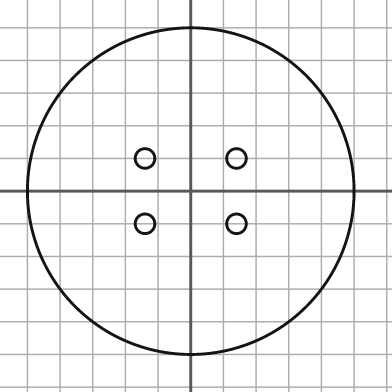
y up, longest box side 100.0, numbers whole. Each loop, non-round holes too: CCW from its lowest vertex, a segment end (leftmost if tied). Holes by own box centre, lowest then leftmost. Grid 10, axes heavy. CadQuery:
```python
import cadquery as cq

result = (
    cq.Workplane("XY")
    .moveTo(0.0, 0.0)
    .circle(50.0)
    .moveTo(-14.0, -10.0)
    .circle(3.0)
    .moveTo(14.0, -10.0)
    .circle(3.0)
    .moveTo(-14.0, 10.0)
    .circle(3.0)
    .moveTo(14.0, 10.0)
    .circle(3.0)
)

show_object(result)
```